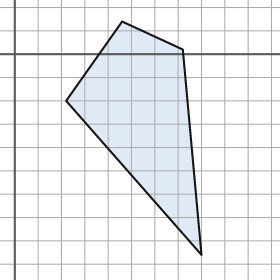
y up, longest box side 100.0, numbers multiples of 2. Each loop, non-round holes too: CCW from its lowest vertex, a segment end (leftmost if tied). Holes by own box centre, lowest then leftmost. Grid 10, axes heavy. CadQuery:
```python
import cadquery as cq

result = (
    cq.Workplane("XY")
    .moveTo(80.0, -86.0)
    .lineTo(72.0, 2.0)
    .lineTo(46.0, 14.0)
    .lineTo(22.0, -20.0)
    .close()
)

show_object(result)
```